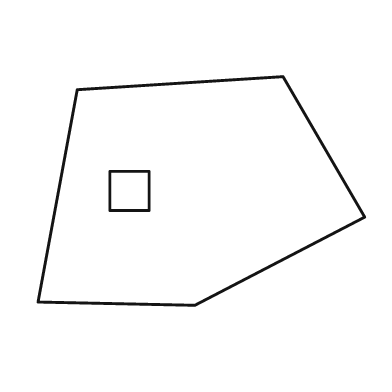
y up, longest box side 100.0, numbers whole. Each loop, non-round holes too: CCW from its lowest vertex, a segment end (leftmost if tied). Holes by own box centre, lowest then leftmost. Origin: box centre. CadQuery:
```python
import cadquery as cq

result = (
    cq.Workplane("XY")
    .moveTo(-2.0, -35.0)
    .lineTo(50.0, -8.0)
    .lineTo(25.0, 35.0)
    .lineTo(-38.0, 31.0)
    .lineTo(-50.0, -34.0)
    .close()
    .moveTo(-28.0, -6.0)
    .lineTo(-16.0, -6.0)
    .lineTo(-16.0, 6.0)
    .lineTo(-28.0, 6.0)
    .close()
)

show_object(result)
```